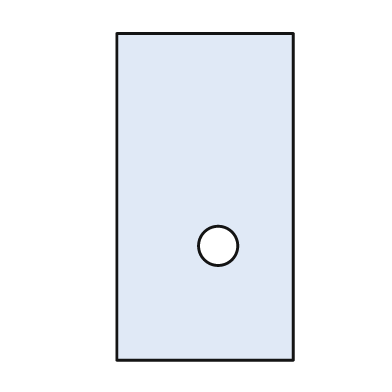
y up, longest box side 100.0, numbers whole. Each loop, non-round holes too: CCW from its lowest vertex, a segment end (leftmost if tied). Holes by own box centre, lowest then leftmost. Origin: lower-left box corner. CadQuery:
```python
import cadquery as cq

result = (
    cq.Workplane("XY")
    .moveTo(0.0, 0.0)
    .lineTo(54.0, 0.0)
    .lineTo(54.0, 100.0)
    .lineTo(0.0, 100.0)
    .close()
    .moveTo(31.0, 35.0)
    .circle(6.0)
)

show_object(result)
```